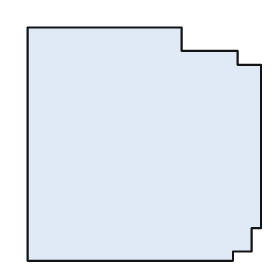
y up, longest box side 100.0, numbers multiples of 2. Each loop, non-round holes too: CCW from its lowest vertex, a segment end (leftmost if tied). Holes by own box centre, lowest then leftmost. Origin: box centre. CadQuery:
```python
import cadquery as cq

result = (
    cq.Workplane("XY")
    .moveTo(-50.0, -50.0)
    .lineTo(38.0, -50.0)
    .lineTo(38.0, -46.0)
    .lineTo(46.0, -46.0)
    .lineTo(46.0, -36.0)
    .lineTo(50.0, -36.0)
    .lineTo(50.0, 34.0)
    .lineTo(40.0, 34.0)
    .lineTo(40.0, 40.0)
    .lineTo(16.0, 40.0)
    .lineTo(16.0, 50.0)
    .lineTo(-50.0, 50.0)
    .close()
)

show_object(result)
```